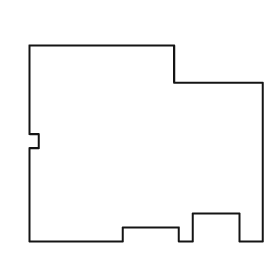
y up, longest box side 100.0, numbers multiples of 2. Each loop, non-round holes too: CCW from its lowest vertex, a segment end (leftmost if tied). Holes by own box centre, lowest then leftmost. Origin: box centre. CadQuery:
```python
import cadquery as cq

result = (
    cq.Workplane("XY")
    .moveTo(-50.0, -42.0)
    .lineTo(-10.0, -42.0)
    .lineTo(-10.0, -36.0)
    .lineTo(14.0, -36.0)
    .lineTo(14.0, -42.0)
    .lineTo(20.0, -42.0)
    .lineTo(20.0, -30.0)
    .lineTo(40.0, -30.0)
    .lineTo(40.0, -42.0)
    .lineTo(50.0, -42.0)
    .lineTo(50.0, 26.0)
    .lineTo(12.0, 26.0)
    .lineTo(12.0, 42.0)
    .lineTo(-50.0, 42.0)
    .lineTo(-50.0, 4.0)
    .lineTo(-46.0, 4.0)
    .lineTo(-46.0, -2.0)
    .lineTo(-50.0, -2.0)
    .close()
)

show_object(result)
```